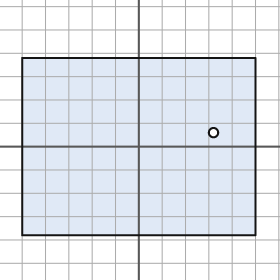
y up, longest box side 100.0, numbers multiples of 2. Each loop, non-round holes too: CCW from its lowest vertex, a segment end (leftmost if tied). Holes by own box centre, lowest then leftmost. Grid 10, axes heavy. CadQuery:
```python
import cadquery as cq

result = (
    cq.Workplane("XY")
    .moveTo(-50.0, -38.0)
    .lineTo(50.0, -38.0)
    .lineTo(50.0, 38.0)
    .lineTo(-50.0, 38.0)
    .close()
    .moveTo(32.0, 6.0)
    .circle(2.0)
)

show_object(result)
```